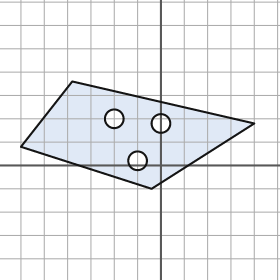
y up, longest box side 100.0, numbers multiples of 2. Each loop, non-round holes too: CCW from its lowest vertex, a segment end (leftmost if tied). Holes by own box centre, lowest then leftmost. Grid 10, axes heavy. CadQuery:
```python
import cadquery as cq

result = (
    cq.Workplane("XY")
    .moveTo(-4.0, -10.0)
    .lineTo(40.0, 18.0)
    .lineTo(-38.0, 36.0)
    .lineTo(-60.0, 8.0)
    .close()
    .moveTo(-10.0, 2.0)
    .circle(4.0)
    .moveTo(0.0, 18.0)
    .circle(4.0)
    .moveTo(-20.0, 20.0)
    .circle(4.0)
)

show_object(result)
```